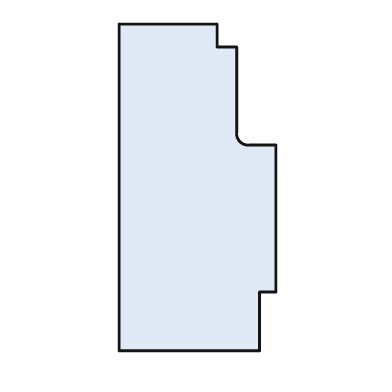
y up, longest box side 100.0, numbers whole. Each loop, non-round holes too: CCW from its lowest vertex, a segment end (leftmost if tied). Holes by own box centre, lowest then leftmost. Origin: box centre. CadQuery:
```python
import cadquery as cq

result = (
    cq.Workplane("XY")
    .moveTo(-24.0, -50.0)
    .lineTo(19.0, -50.0)
    .lineTo(19.0, -32.0)
    .lineTo(24.0, -32.0)
    .lineTo(24.0, 13.0)
    .lineTo(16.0, 13.0)
    .threePointArc((13.0, 14.0), (12.0, 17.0))
    .lineTo(12.0, 43.0)
    .lineTo(6.0, 43.0)
    .lineTo(6.0, 50.0)
    .lineTo(-24.0, 50.0)
    .close()
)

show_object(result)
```